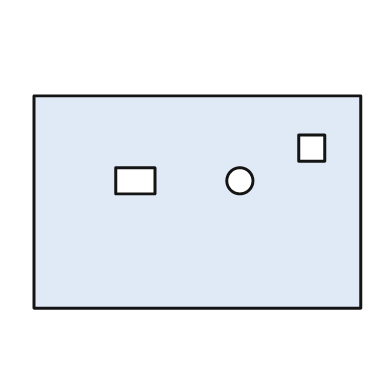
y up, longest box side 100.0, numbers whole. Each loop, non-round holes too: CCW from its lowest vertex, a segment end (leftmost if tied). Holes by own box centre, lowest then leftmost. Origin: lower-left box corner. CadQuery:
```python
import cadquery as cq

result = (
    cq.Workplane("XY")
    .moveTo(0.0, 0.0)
    .lineTo(100.0, 0.0)
    .lineTo(100.0, 65.0)
    .lineTo(0.0, 65.0)
    .close()
    .moveTo(25.0, 35.0)
    .lineTo(37.0, 35.0)
    .lineTo(37.0, 43.0)
    .lineTo(25.0, 43.0)
    .close()
    .moveTo(63.0, 39.0)
    .circle(4.0)
    .moveTo(81.0, 45.0)
    .lineTo(89.0, 45.0)
    .lineTo(89.0, 53.0)
    .lineTo(81.0, 53.0)
    .close()
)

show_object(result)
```